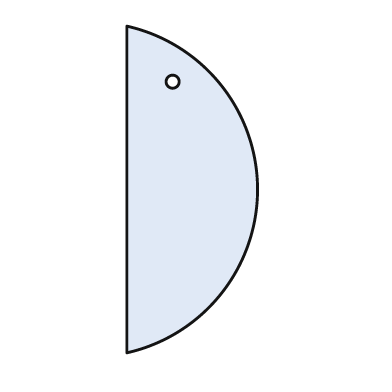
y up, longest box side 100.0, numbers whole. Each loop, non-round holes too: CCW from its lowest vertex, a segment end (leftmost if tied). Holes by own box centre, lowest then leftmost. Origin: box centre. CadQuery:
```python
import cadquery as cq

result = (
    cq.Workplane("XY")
    .moveTo(-20.0, -50.0)
    .threePointArc((20.0, 0.0), (-20.0, 50.0))
    .close()
    .moveTo(-6.0, 33.0)
    .circle(2.0)
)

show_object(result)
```